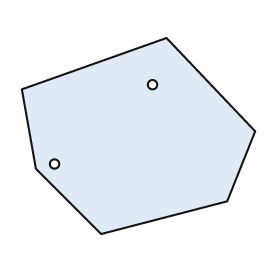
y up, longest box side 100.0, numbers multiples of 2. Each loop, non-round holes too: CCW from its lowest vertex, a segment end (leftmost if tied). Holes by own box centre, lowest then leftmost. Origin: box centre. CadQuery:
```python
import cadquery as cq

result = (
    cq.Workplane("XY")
    .moveTo(-16.0, -42.0)
    .lineTo(38.0, -28.0)
    .lineTo(50.0, 2.0)
    .lineTo(12.0, 42.0)
    .lineTo(-50.0, 20.0)
    .lineTo(-44.0, -14.0)
    .close()
    .moveTo(-36.0, -12.0)
    .circle(2.0)
    .moveTo(6.0, 22.0)
    .circle(2.0)
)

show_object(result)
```